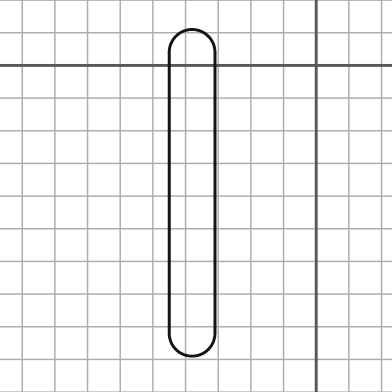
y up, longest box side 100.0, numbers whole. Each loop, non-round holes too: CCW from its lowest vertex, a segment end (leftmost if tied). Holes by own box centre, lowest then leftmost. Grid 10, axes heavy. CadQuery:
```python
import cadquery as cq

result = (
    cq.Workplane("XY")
    .moveTo(-45.0, -82.0)
    .threePointArc((-38.0, -89.0), (-31.0, -82.0))
    .lineTo(-31.0, 4.0)
    .threePointArc((-38.0, 11.0), (-45.0, 4.0))
    .close()
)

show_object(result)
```